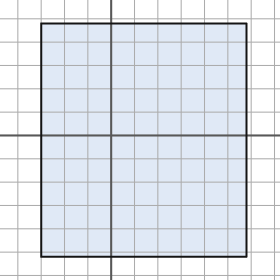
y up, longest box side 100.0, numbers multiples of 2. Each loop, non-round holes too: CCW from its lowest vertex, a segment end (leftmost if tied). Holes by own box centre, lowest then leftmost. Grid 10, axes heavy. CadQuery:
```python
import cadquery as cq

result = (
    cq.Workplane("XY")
    .moveTo(-30.0, -52.0)
    .lineTo(58.0, -52.0)
    .lineTo(58.0, 48.0)
    .lineTo(-30.0, 48.0)
    .close()
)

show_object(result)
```